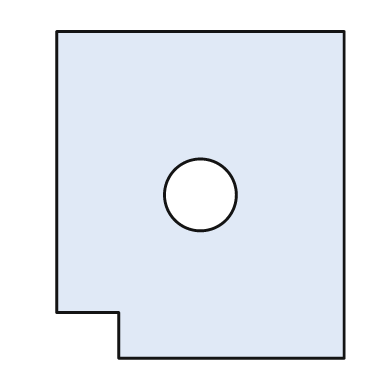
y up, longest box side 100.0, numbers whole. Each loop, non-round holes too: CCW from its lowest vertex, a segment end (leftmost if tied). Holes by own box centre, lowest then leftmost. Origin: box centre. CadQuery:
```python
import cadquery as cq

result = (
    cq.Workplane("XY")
    .moveTo(-25.0, -50.0)
    .lineTo(44.0, -50.0)
    .lineTo(44.0, 50.0)
    .lineTo(-44.0, 50.0)
    .lineTo(-44.0, -36.0)
    .lineTo(-25.0, -36.0)
    .close()
    .moveTo(0.0, 0.0)
    .circle(11.0)
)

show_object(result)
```